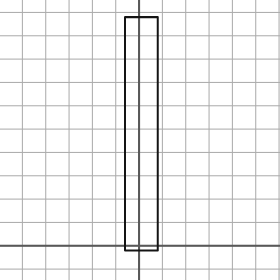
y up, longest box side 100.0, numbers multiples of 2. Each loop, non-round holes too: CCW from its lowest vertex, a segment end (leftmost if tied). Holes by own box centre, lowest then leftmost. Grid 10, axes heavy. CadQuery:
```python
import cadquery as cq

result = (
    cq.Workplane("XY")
    .moveTo(-6.0, -2.0)
    .lineTo(8.0, -2.0)
    .lineTo(8.0, 98.0)
    .lineTo(-6.0, 98.0)
    .close()
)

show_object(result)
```